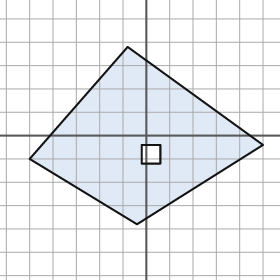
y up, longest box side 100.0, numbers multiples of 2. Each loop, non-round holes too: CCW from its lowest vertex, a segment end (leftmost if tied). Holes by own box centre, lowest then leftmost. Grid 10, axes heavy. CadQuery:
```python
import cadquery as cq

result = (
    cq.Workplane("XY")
    .moveTo(-4.0, -38.0)
    .lineTo(50.0, -4.0)
    .lineTo(-8.0, 38.0)
    .lineTo(-50.0, -10.0)
    .close()
    .moveTo(-2.0, -12.0)
    .lineTo(6.0, -12.0)
    .lineTo(6.0, -4.0)
    .lineTo(-2.0, -4.0)
    .close()
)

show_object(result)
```